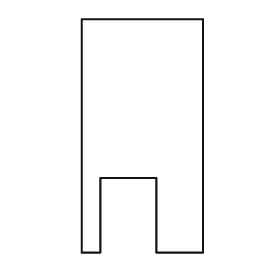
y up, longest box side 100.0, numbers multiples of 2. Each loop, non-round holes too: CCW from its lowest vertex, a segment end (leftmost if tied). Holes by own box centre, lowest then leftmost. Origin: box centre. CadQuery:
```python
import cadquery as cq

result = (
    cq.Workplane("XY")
    .moveTo(-26.0, -50.0)
    .lineTo(-18.0, -50.0)
    .lineTo(-18.0, -18.0)
    .lineTo(6.0, -18.0)
    .lineTo(6.0, -50.0)
    .lineTo(26.0, -50.0)
    .lineTo(26.0, 50.0)
    .lineTo(-26.0, 50.0)
    .close()
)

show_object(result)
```